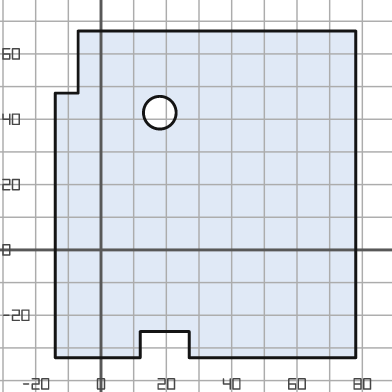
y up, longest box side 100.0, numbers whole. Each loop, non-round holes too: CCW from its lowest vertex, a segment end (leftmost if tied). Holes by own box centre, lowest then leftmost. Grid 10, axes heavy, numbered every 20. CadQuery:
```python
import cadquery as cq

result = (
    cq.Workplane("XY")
    .moveTo(-14.0, -33.0)
    .lineTo(12.0, -33.0)
    .lineTo(12.0, -25.0)
    .lineTo(27.0, -25.0)
    .lineTo(27.0, -33.0)
    .lineTo(78.0, -33.0)
    .lineTo(78.0, 67.0)
    .lineTo(-7.0, 67.0)
    .lineTo(-7.0, 48.0)
    .lineTo(-14.0, 48.0)
    .close()
    .moveTo(18.0, 42.0)
    .circle(5.0)
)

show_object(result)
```